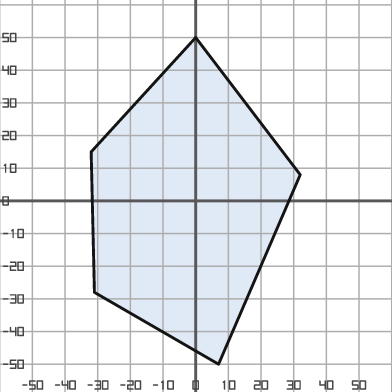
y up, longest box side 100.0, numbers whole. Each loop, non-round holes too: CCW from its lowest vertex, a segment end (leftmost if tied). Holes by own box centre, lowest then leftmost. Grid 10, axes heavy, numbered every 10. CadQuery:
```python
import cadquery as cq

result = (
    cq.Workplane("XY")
    .moveTo(7.0, -50.0)
    .lineTo(32.0, 8.0)
    .lineTo(0.0, 50.0)
    .lineTo(-32.0, 15.0)
    .lineTo(-31.0, -28.0)
    .close()
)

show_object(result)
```